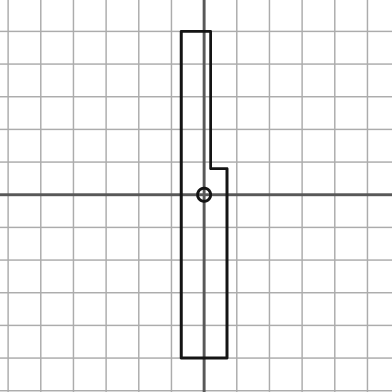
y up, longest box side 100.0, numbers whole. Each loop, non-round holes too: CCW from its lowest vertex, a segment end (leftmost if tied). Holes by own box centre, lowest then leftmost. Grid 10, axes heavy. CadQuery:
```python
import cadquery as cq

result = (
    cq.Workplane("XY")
    .moveTo(-7.0, -50.0)
    .lineTo(7.0, -50.0)
    .lineTo(7.0, 8.0)
    .lineTo(2.0, 8.0)
    .lineTo(2.0, 50.0)
    .lineTo(-7.0, 50.0)
    .close()
    .moveTo(0.0, 0.0)
    .circle(2.0)
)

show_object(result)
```